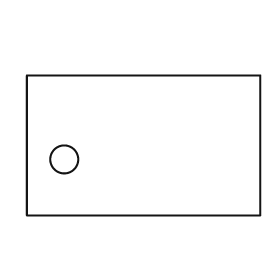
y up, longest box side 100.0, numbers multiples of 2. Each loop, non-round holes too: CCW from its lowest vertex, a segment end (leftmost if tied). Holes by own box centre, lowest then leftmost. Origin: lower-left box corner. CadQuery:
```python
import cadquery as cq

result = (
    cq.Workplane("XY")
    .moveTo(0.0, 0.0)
    .lineTo(100.0, 0.0)
    .lineTo(100.0, 60.0)
    .lineTo(0.0, 60.0)
    .close()
    .moveTo(16.0, 24.0)
    .circle(6.0)
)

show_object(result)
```